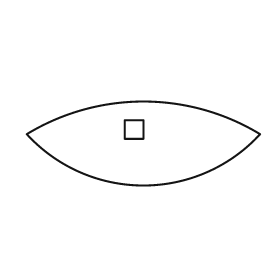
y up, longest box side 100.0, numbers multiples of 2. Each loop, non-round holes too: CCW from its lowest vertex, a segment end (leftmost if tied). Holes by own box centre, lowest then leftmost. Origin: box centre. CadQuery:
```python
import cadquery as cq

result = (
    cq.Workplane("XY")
    .moveTo(-50.0, 4.0)
    .threePointArc((0.0, -18.0), (50.0, 4.0))
    .threePointArc((0.0, 18.0), (-50.0, 4.0))
    .close()
    .moveTo(-8.0, 2.0)
    .lineTo(0.0, 2.0)
    .lineTo(0.0, 10.0)
    .lineTo(-8.0, 10.0)
    .close()
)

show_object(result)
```